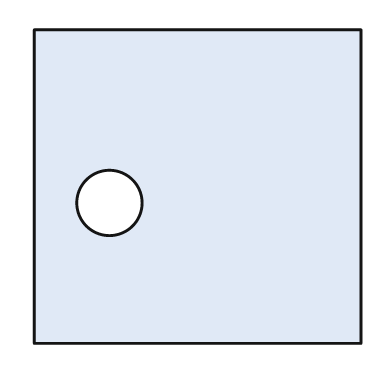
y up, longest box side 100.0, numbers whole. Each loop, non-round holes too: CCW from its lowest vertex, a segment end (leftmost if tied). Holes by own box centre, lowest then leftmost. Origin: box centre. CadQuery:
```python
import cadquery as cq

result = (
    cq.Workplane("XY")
    .moveTo(-50.0, -48.0)
    .lineTo(50.0, -48.0)
    .lineTo(50.0, 48.0)
    .lineTo(-50.0, 48.0)
    .close()
    .moveTo(-27.0, -5.0)
    .circle(10.0)
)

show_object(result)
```